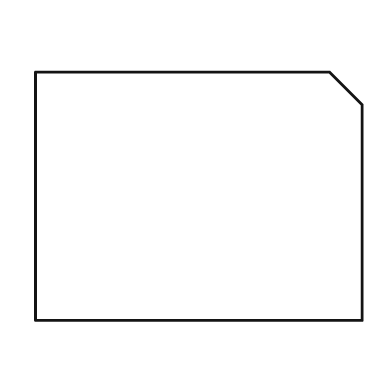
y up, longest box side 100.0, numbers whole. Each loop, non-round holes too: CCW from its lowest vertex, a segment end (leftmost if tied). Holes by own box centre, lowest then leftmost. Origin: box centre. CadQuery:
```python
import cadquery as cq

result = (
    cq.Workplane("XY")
    .moveTo(-50.0, -38.0)
    .lineTo(50.0, -38.0)
    .lineTo(50.0, 28.0)
    .lineTo(40.0, 38.0)
    .lineTo(-50.0, 38.0)
    .close()
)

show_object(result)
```